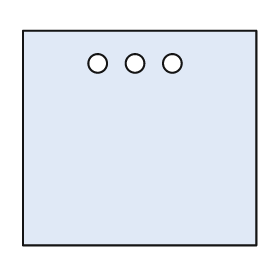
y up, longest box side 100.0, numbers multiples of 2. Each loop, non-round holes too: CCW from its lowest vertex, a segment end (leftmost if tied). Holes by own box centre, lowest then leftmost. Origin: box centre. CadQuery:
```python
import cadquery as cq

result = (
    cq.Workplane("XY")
    .moveTo(-50.0, -46.0)
    .lineTo(50.0, -46.0)
    .lineTo(50.0, 46.0)
    .lineTo(-50.0, 46.0)
    .close()
    .moveTo(-18.0, 32.0)
    .circle(4.0)
    .moveTo(-2.0, 32.0)
    .circle(4.0)
    .moveTo(14.0, 32.0)
    .circle(4.0)
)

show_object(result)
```